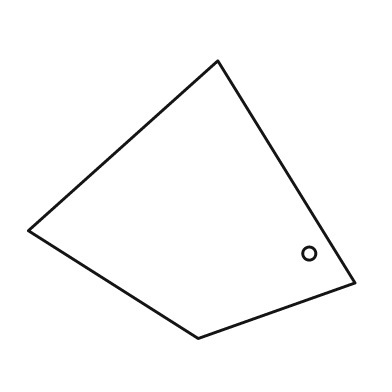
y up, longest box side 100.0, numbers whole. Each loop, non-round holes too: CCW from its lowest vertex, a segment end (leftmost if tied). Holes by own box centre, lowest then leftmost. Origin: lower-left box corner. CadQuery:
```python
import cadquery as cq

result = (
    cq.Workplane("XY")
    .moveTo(52.0, 0.0)
    .lineTo(100.0, 17.0)
    .lineTo(58.0, 85.0)
    .lineTo(0.0, 33.0)
    .close()
    .moveTo(86.0, 26.0)
    .circle(2.0)
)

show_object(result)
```